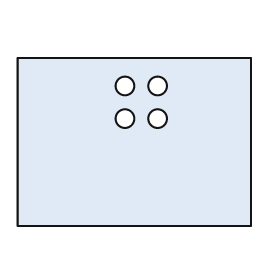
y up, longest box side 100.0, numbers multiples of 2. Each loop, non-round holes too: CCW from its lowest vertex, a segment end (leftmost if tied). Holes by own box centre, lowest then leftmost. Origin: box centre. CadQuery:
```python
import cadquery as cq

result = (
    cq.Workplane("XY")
    .moveTo(-50.0, -36.0)
    .lineTo(50.0, -36.0)
    .lineTo(50.0, 36.0)
    .lineTo(-50.0, 36.0)
    .close()
    .moveTo(-4.0, 10.0)
    .circle(4.0)
    .moveTo(10.0, 10.0)
    .circle(4.0)
    .moveTo(-4.0, 24.0)
    .circle(4.0)
    .moveTo(10.0, 24.0)
    .circle(4.0)
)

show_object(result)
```